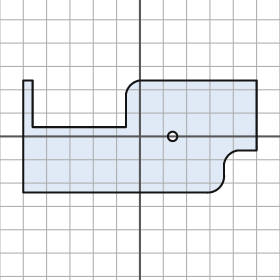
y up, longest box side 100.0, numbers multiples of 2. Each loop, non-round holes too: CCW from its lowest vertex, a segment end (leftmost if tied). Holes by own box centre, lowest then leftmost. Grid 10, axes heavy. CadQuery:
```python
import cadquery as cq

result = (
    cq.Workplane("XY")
    .moveTo(-50.0, -24.0)
    .lineTo(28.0, -24.0)
    .threePointArc((34.0, -22.0), (36.0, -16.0))
    .lineTo(36.0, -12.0)
    .threePointArc((38.0, -8.0), (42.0, -6.0))
    .lineTo(50.0, -6.0)
    .lineTo(50.0, 24.0)
    .lineTo(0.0, 24.0)
    .threePointArc((-4.0, 22.0), (-6.0, 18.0))
    .lineTo(-6.0, 4.0)
    .lineTo(-46.0, 4.0)
    .lineTo(-46.0, 24.0)
    .lineTo(-50.0, 24.0)
    .close()
    .moveTo(14.0, 0.0)
    .circle(2.0)
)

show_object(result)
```